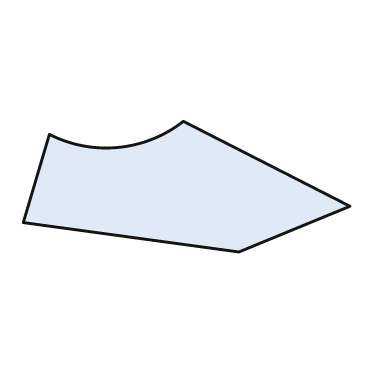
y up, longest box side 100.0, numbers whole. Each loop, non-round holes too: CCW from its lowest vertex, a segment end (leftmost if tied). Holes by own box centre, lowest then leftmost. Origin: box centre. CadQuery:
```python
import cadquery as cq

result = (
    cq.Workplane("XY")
    .moveTo(16.0, -20.0)
    .lineTo(50.0, -6.0)
    .lineTo(-1.0, 20.0)
    .threePointArc((-21.0, 12.0), (-42.0, 16.0))
    .lineTo(-50.0, -11.0)
    .close()
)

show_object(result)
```